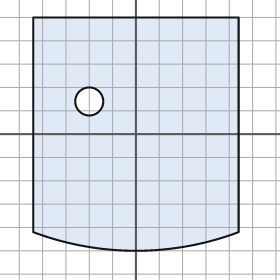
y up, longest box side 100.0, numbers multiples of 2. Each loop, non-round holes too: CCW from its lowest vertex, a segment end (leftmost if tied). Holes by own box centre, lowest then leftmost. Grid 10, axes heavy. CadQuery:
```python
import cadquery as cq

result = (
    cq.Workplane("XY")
    .moveTo(-44.0, -42.0)
    .threePointArc((0.0, -50.0), (44.0, -42.0))
    .lineTo(44.0, 50.0)
    .lineTo(-44.0, 50.0)
    .close()
    .moveTo(-20.0, 14.0)
    .circle(6.0)
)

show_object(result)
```